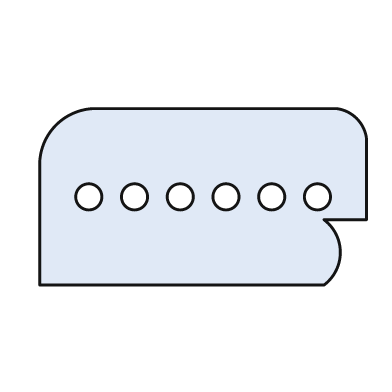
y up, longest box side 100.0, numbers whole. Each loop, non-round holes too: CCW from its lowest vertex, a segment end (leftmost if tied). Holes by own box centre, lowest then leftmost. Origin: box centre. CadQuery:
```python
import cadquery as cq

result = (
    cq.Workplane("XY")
    .moveTo(-50.0, -27.0)
    .lineTo(37.0, -27.0)
    .threePointArc((42.0, -17.0), (37.0, -7.0))
    .lineTo(50.0, -7.0)
    .lineTo(50.0, 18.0)
    .threePointArc((47.0, 24.0), (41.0, 27.0))
    .lineTo(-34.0, 27.0)
    .threePointArc((-45.0, 22.0), (-50.0, 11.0))
    .close()
    .moveTo(-35.0, 0.0)
    .circle(4.0)
    .moveTo(-21.0, 0.0)
    .circle(4.0)
    .moveTo(-7.0, 0.0)
    .circle(4.0)
    .moveTo(7.0, 0.0)
    .circle(4.0)
    .moveTo(21.0, 0.0)
    .circle(4.0)
    .moveTo(35.0, 0.0)
    .circle(4.0)
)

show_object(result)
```